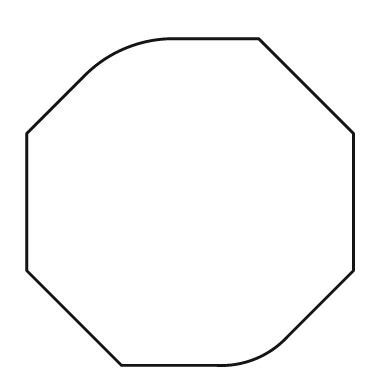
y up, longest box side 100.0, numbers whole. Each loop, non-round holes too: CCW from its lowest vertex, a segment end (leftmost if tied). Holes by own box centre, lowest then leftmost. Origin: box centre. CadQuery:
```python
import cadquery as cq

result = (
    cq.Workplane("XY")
    .moveTo(-21.0, -50.0)
    .lineTo(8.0, -50.0)
    .threePointArc((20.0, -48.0), (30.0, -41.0))
    .lineTo(50.0, -21.0)
    .lineTo(50.0, 21.0)
    .lineTo(21.0, 50.0)
    .lineTo(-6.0, 50.0)
    .threePointArc((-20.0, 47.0), (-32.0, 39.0))
    .lineTo(-50.0, 21.0)
    .lineTo(-50.0, -21.0)
    .close()
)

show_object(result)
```